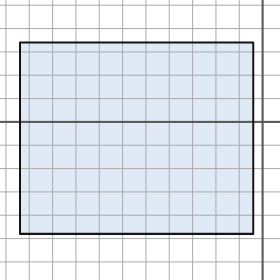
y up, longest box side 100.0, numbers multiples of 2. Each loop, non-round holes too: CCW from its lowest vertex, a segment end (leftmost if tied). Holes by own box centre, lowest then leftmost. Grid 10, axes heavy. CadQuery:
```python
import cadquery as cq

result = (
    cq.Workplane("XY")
    .moveTo(-104.0, -48.0)
    .lineTo(-4.0, -48.0)
    .lineTo(-4.0, 34.0)
    .lineTo(-104.0, 34.0)
    .close()
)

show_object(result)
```